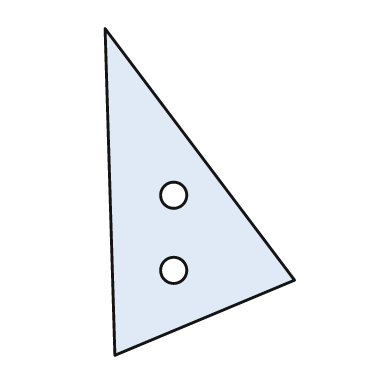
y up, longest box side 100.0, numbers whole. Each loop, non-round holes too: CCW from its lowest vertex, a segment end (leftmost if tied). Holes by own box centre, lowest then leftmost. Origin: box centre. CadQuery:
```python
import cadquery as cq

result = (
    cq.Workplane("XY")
    .moveTo(-26.0, -50.0)
    .lineTo(29.0, -27.0)
    .lineTo(-29.0, 50.0)
    .close()
    .moveTo(-8.0, -24.0)
    .circle(4.0)
    .moveTo(-8.0, -1.0)
    .circle(4.0)
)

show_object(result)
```